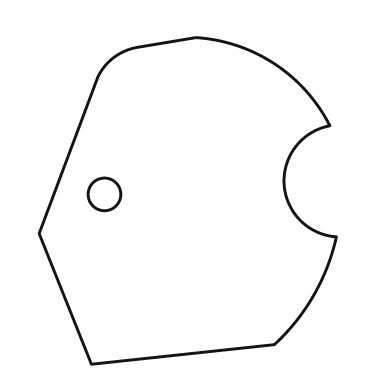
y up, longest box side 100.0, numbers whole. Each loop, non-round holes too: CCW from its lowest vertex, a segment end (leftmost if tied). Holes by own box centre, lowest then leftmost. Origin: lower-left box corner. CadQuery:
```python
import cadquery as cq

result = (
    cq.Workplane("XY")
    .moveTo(16.0, 0.0)
    .lineTo(72.0, 6.0)
    .threePointArc((84.0, 21.0), (91.0, 39.0))
    .threePointArc((75.0, 55.0), (89.0, 73.0))
    .threePointArc((72.0, 92.0), (48.0, 100.0))
    .lineTo(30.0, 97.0)
    .threePointArc((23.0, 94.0), (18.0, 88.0))
    .lineTo(0.0, 40.0)
    .close()
    .moveTo(20.0, 52.0)
    .circle(5.0)
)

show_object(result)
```